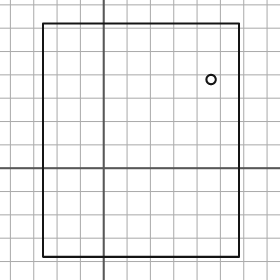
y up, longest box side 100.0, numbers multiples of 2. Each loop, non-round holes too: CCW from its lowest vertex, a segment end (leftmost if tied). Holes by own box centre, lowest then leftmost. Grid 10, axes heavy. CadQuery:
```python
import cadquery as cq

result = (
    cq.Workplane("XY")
    .moveTo(-26.0, -38.0)
    .lineTo(58.0, -38.0)
    .lineTo(58.0, 62.0)
    .lineTo(-26.0, 62.0)
    .close()
    .moveTo(46.0, 38.0)
    .circle(2.0)
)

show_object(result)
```